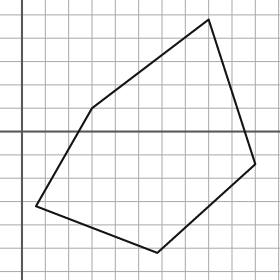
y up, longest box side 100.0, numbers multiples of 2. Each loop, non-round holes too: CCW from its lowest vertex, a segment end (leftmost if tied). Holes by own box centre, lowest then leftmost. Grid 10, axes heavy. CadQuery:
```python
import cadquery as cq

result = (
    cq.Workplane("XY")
    .moveTo(58.0, -52.0)
    .lineTo(100.0, -14.0)
    .lineTo(80.0, 48.0)
    .lineTo(30.0, 10.0)
    .lineTo(6.0, -32.0)
    .close()
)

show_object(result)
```